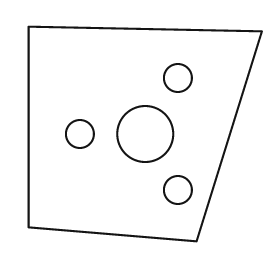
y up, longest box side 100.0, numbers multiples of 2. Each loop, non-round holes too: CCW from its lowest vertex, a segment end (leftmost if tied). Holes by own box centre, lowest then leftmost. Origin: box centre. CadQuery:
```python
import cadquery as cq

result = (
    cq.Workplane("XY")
    .moveTo(22.0, -46.0)
    .lineTo(50.0, 44.0)
    .lineTo(-50.0, 46.0)
    .lineTo(-50.0, -40.0)
    .close()
    .moveTo(14.0, -24.0)
    .circle(6.0)
    .moveTo(-28.0, 0.0)
    .circle(6.0)
    .moveTo(0.0, 0.0)
    .circle(12.0)
    .moveTo(14.0, 24.0)
    .circle(6.0)
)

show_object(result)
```